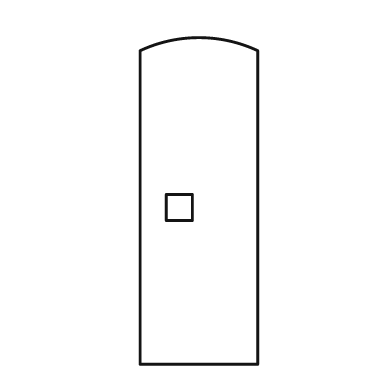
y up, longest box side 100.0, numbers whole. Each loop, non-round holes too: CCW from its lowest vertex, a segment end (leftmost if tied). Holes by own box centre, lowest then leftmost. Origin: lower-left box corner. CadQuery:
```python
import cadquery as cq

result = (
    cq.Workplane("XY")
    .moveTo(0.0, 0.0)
    .lineTo(36.0, 0.0)
    .lineTo(36.0, 96.0)
    .threePointArc((18.0, 100.0), (0.0, 96.0))
    .close()
    .moveTo(8.0, 44.0)
    .lineTo(16.0, 44.0)
    .lineTo(16.0, 52.0)
    .lineTo(8.0, 52.0)
    .close()
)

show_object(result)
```